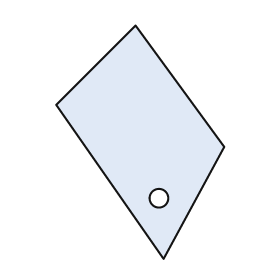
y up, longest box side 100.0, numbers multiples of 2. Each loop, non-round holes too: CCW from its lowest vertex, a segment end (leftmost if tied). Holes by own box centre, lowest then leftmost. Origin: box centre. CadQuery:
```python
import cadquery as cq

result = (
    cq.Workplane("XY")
    .moveTo(10.0, -50.0)
    .lineTo(36.0, -2.0)
    .lineTo(-2.0, 50.0)
    .lineTo(-36.0, 16.0)
    .close()
    .moveTo(8.0, -24.0)
    .circle(4.0)
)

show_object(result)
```